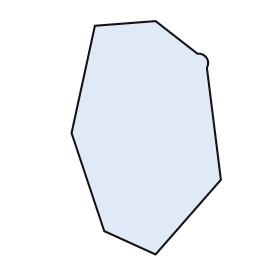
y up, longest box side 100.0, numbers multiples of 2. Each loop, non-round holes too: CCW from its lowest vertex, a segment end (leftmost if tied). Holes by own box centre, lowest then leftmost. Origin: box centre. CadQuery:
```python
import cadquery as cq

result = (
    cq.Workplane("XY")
    .moveTo(4.0, -50.0)
    .lineTo(32.0, -18.0)
    .lineTo(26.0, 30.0)
    .threePointArc((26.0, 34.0), (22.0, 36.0))
    .lineTo(4.0, 50.0)
    .lineTo(-22.0, 48.0)
    .lineTo(-32.0, 2.0)
    .lineTo(-18.0, -40.0)
    .close()
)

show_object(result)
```